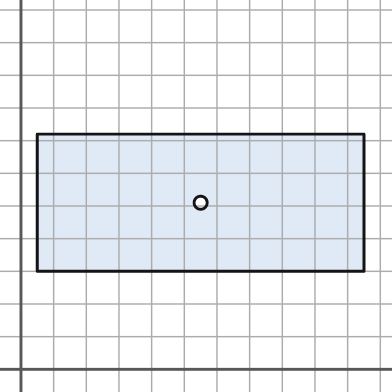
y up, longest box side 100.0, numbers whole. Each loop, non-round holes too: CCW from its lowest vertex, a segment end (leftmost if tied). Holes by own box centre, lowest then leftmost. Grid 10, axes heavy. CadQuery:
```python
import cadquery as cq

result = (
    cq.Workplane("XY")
    .moveTo(5.0, 30.0)
    .lineTo(105.0, 30.0)
    .lineTo(105.0, 72.0)
    .lineTo(5.0, 72.0)
    .close()
    .moveTo(55.0, 51.0)
    .circle(2.0)
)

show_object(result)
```